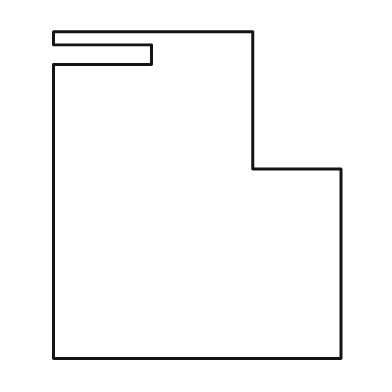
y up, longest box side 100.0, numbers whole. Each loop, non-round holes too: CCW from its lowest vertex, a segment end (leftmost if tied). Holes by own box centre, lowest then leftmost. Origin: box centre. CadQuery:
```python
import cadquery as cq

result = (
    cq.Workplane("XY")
    .moveTo(-44.0, -50.0)
    .lineTo(44.0, -50.0)
    .lineTo(44.0, 8.0)
    .lineTo(17.0, 8.0)
    .lineTo(17.0, 50.0)
    .lineTo(-44.0, 50.0)
    .lineTo(-44.0, 46.0)
    .lineTo(-14.0, 46.0)
    .lineTo(-14.0, 40.0)
    .lineTo(-44.0, 40.0)
    .close()
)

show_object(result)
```